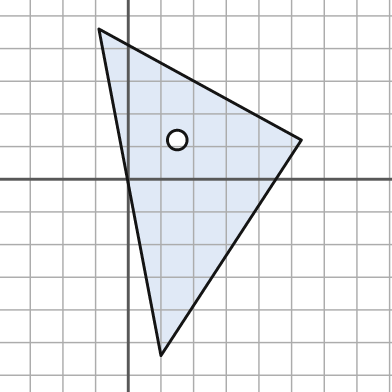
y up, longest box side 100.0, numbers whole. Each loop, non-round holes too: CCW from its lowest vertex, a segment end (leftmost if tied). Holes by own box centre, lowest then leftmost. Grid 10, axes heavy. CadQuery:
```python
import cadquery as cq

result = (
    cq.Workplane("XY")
    .moveTo(10.0, -54.0)
    .lineTo(53.0, 12.0)
    .lineTo(-9.0, 46.0)
    .close()
    .moveTo(15.0, 12.0)
    .circle(3.0)
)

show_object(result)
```